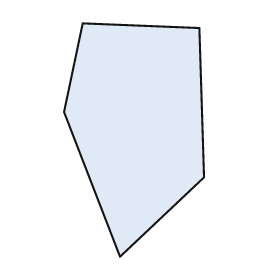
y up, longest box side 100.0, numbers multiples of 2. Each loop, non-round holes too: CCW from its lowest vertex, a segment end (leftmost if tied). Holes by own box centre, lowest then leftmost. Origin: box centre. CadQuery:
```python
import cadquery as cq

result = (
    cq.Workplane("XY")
    .moveTo(-6.0, -50.0)
    .lineTo(30.0, -16.0)
    .lineTo(28.0, 48.0)
    .lineTo(-22.0, 50.0)
    .lineTo(-30.0, 12.0)
    .close()
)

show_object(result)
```